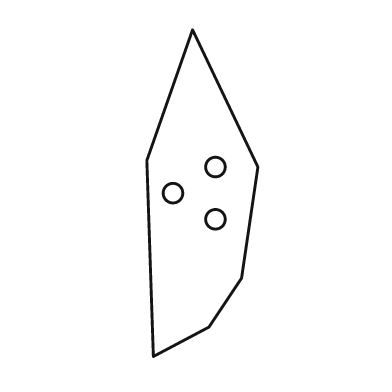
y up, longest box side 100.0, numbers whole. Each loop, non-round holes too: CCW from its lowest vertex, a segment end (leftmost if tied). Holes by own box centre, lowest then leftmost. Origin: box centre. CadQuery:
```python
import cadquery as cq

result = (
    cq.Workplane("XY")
    .moveTo(-15.0, -50.0)
    .lineTo(2.0, -41.0)
    .lineTo(12.0, -26.0)
    .lineTo(17.0, 8.0)
    .lineTo(-3.0, 50.0)
    .lineTo(-17.0, 10.0)
    .close()
    .moveTo(4.0, -8.0)
    .circle(3.0)
    .moveTo(-9.0, 0.0)
    .circle(3.0)
    .moveTo(4.0, 8.0)
    .circle(3.0)
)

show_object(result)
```